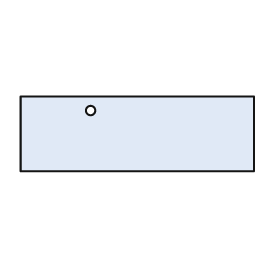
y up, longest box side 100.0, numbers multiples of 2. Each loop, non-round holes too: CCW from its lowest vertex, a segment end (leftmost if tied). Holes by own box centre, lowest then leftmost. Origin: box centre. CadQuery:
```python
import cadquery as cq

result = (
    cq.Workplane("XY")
    .moveTo(-50.0, -16.0)
    .lineTo(50.0, -16.0)
    .lineTo(50.0, 16.0)
    .lineTo(-50.0, 16.0)
    .close()
    .moveTo(-20.0, 10.0)
    .circle(2.0)
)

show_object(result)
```